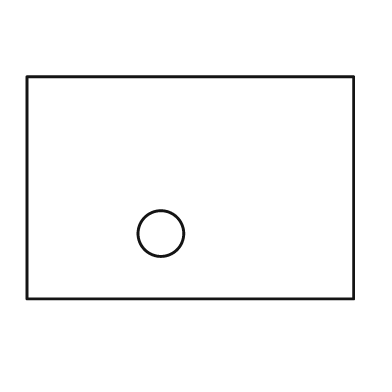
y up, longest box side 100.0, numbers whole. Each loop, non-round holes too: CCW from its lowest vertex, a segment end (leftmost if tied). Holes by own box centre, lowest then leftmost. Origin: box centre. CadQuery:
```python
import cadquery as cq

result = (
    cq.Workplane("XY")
    .moveTo(-50.0, -34.0)
    .lineTo(50.0, -34.0)
    .lineTo(50.0, 34.0)
    .lineTo(-50.0, 34.0)
    .close()
    .moveTo(-9.0, -14.0)
    .circle(7.0)
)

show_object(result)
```